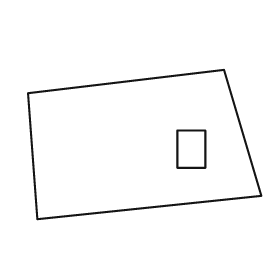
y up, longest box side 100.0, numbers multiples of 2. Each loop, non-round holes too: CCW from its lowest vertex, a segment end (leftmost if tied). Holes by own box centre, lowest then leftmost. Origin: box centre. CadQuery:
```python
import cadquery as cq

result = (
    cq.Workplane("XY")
    .moveTo(-46.0, -32.0)
    .lineTo(50.0, -22.0)
    .lineTo(34.0, 32.0)
    .lineTo(-50.0, 22.0)
    .close()
    .moveTo(14.0, -10.0)
    .lineTo(26.0, -10.0)
    .lineTo(26.0, 6.0)
    .lineTo(14.0, 6.0)
    .close()
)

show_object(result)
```